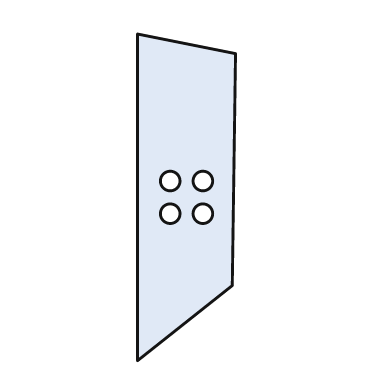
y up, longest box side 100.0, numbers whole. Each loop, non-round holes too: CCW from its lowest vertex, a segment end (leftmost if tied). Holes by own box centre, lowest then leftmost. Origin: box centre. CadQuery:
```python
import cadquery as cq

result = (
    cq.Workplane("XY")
    .moveTo(-15.0, -50.0)
    .lineTo(14.0, -27.0)
    .lineTo(15.0, 44.0)
    .lineTo(-15.0, 50.0)
    .close()
    .moveTo(-5.0, -5.0)
    .circle(3.0)
    .moveTo(5.0, -5.0)
    .circle(3.0)
    .moveTo(-5.0, 5.0)
    .circle(3.0)
    .moveTo(5.0, 5.0)
    .circle(3.0)
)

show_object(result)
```